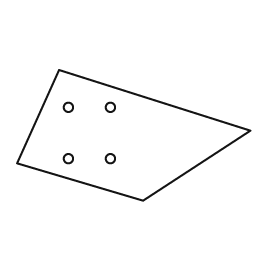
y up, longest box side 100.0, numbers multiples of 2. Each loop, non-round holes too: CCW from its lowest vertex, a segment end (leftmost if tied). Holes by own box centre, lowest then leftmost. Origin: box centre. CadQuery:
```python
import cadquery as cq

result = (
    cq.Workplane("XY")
    .moveTo(4.0, -28.0)
    .lineTo(50.0, 2.0)
    .lineTo(-32.0, 28.0)
    .lineTo(-50.0, -12.0)
    .close()
    .moveTo(-28.0, -10.0)
    .circle(2.0)
    .moveTo(-10.0, -10.0)
    .circle(2.0)
    .moveTo(-28.0, 12.0)
    .circle(2.0)
    .moveTo(-10.0, 12.0)
    .circle(2.0)
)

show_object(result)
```